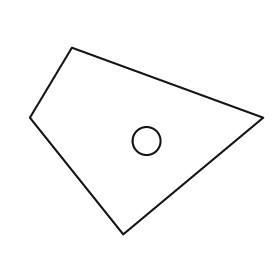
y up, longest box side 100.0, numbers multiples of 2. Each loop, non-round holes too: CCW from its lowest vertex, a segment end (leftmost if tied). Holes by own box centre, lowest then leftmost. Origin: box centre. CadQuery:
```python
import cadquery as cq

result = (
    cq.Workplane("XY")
    .moveTo(-10.0, -40.0)
    .lineTo(50.0, 10.0)
    .lineTo(-32.0, 40.0)
    .lineTo(-50.0, 10.0)
    .close()
    .moveTo(0.0, 0.0)
    .circle(6.0)
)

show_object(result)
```